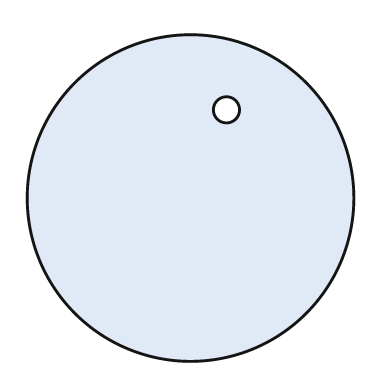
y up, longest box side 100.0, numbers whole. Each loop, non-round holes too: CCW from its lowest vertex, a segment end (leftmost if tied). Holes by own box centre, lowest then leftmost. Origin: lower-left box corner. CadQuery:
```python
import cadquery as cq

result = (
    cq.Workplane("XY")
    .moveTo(50.0, 50.0)
    .circle(50.0)
    .moveTo(61.0, 77.0)
    .circle(4.0)
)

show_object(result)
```